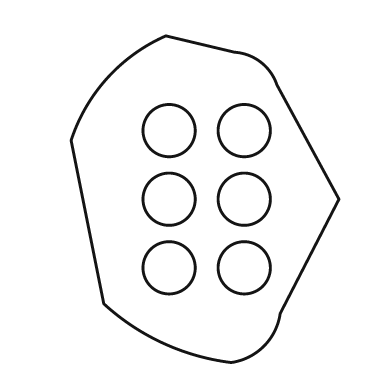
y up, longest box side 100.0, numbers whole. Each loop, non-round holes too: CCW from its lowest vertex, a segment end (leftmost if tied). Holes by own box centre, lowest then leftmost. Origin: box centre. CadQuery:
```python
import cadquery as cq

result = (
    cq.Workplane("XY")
    .moveTo(8.0, -50.0)
    .threePointArc((18.0, -45.0), (23.0, -35.0))
    .lineTo(41.0, 0.0)
    .lineTo(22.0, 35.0)
    .threePointArc((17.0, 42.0), (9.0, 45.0))
    .lineTo(-12.0, 50.0)
    .threePointArc((-30.0, 37.0), (-41.0, 18.0))
    .lineTo(-31.0, -32.0)
    .threePointArc((-13.0, -44.0), (8.0, -50.0))
    .close()
    .moveTo(-11.0, -21.0)
    .circle(8.0)
    .moveTo(12.0, -21.0)
    .circle(8.0)
    .moveTo(-11.0, 0.0)
    .circle(8.0)
    .moveTo(12.0, 0.0)
    .circle(8.0)
    .moveTo(-11.0, 21.0)
    .circle(8.0)
    .moveTo(12.0, 21.0)
    .circle(8.0)
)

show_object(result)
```